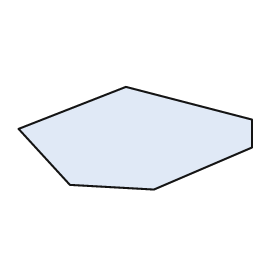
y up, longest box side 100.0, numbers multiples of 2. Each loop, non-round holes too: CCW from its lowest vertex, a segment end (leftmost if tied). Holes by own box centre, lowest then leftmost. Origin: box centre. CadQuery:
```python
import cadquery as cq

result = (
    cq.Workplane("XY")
    .moveTo(8.0, -22.0)
    .lineTo(50.0, -4.0)
    .lineTo(50.0, 8.0)
    .lineTo(-4.0, 22.0)
    .lineTo(-50.0, 4.0)
    .lineTo(-28.0, -20.0)
    .close()
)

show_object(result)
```